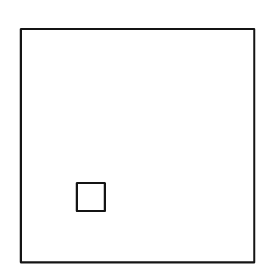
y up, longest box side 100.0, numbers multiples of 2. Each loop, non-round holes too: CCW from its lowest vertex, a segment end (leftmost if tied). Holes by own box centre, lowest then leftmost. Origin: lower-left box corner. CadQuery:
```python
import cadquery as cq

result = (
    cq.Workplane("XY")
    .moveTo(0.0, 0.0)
    .lineTo(100.0, 0.0)
    .lineTo(100.0, 100.0)
    .lineTo(0.0, 100.0)
    .close()
    .moveTo(24.0, 22.0)
    .lineTo(36.0, 22.0)
    .lineTo(36.0, 34.0)
    .lineTo(24.0, 34.0)
    .close()
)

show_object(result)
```